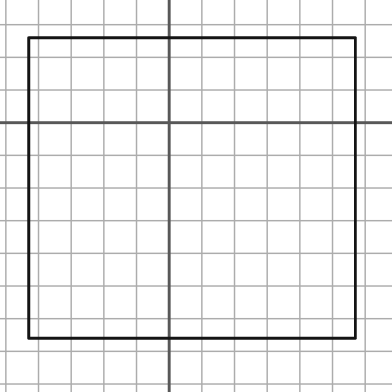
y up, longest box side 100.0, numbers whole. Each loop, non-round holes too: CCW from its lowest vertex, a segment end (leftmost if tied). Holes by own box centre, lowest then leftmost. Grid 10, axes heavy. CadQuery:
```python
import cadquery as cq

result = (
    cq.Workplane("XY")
    .moveTo(-43.0, -66.0)
    .lineTo(57.0, -66.0)
    .lineTo(57.0, 26.0)
    .lineTo(-43.0, 26.0)
    .close()
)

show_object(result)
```